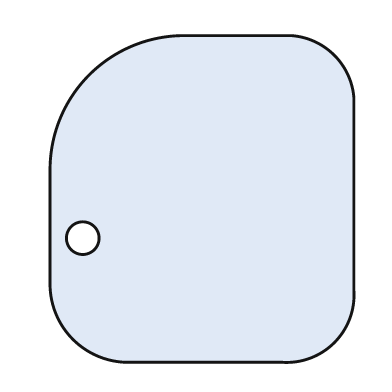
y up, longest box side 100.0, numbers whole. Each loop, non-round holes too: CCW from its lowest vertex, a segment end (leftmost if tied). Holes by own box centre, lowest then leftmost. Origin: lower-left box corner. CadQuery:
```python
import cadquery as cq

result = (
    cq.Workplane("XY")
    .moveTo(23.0, 0.0)
    .lineTo(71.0, 0.0)
    .threePointArc((87.0, 6.0), (93.0, 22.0))
    .lineTo(93.0, 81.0)
    .threePointArc((87.0, 94.0), (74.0, 100.0))
    .lineTo(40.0, 100.0)
    .threePointArc((12.0, 88.0), (0.0, 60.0))
    .lineTo(0.0, 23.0)
    .threePointArc((7.0, 7.0), (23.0, 0.0))
    .close()
    .moveTo(10.0, 38.0)
    .circle(5.0)
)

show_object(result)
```